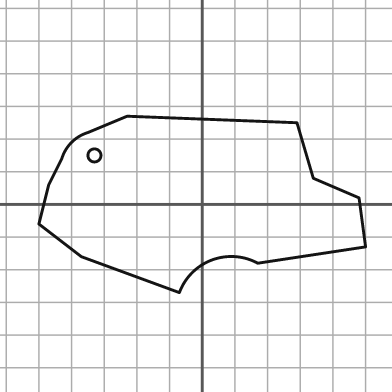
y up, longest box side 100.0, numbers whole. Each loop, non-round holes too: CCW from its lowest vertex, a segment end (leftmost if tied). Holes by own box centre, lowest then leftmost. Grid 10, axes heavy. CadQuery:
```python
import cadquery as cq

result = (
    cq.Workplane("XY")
    .moveTo(-7.0, -27.0)
    .threePointArc((3.0, -17.0), (17.0, -18.0))
    .lineTo(50.0, -13.0)
    .lineTo(48.0, 2.0)
    .lineTo(34.0, 8.0)
    .lineTo(29.0, 25.0)
    .lineTo(-23.0, 27.0)
    .lineTo(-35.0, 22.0)
    .threePointArc((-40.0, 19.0), (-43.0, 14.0))
    .lineTo(-47.0, 6.0)
    .lineTo(-50.0, -6.0)
    .lineTo(-37.0, -16.0)
    .close()
    .moveTo(-33.0, 15.0)
    .circle(2.0)
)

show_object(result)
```